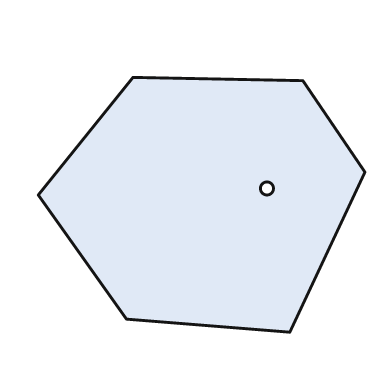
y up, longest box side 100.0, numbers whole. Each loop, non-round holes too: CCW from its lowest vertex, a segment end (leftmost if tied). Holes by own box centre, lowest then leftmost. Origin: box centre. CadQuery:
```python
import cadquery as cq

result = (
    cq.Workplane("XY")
    .moveTo(27.0, -39.0)
    .lineTo(50.0, 10.0)
    .lineTo(31.0, 38.0)
    .lineTo(-21.0, 39.0)
    .lineTo(-50.0, 3.0)
    .lineTo(-23.0, -35.0)
    .close()
    .moveTo(20.0, 5.0)
    .circle(2.0)
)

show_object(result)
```